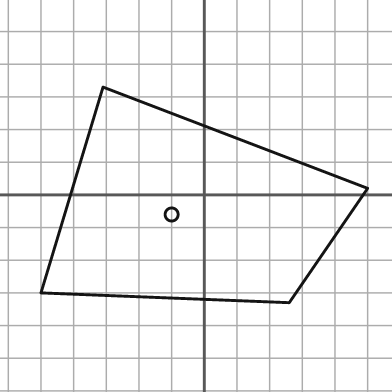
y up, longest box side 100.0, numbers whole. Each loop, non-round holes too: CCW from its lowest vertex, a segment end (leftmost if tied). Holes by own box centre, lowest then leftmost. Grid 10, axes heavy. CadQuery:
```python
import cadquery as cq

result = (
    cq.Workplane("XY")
    .moveTo(26.0, -33.0)
    .lineTo(50.0, 2.0)
    .lineTo(-31.0, 33.0)
    .lineTo(-50.0, -30.0)
    .close()
    .moveTo(-10.0, -6.0)
    .circle(2.0)
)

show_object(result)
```